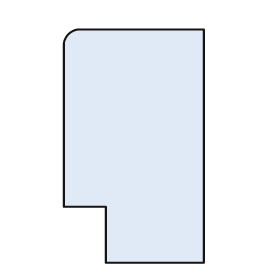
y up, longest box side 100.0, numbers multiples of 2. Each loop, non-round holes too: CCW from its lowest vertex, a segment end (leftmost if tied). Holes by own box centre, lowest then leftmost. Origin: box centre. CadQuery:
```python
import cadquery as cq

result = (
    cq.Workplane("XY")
    .moveTo(-12.0, -50.0)
    .lineTo(30.0, -50.0)
    .lineTo(30.0, 50.0)
    .lineTo(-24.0, 50.0)
    .threePointArc((-28.0, 48.0), (-30.0, 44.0))
    .lineTo(-30.0, -26.0)
    .lineTo(-12.0, -26.0)
    .close()
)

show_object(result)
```